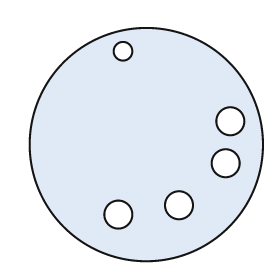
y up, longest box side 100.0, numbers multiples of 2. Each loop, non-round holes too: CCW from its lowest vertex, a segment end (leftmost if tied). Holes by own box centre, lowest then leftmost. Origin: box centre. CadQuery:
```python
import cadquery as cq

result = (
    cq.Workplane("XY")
    .moveTo(0.0, 0.0)
    .circle(50.0)
    .moveTo(-12.0, -30.0)
    .circle(6.0)
    .moveTo(14.0, -26.0)
    .circle(6.0)
    .moveTo(34.0, -8.0)
    .circle(6.0)
    .moveTo(36.0, 10.0)
    .circle(6.0)
    .moveTo(-10.0, 40.0)
    .circle(4.0)
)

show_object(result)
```